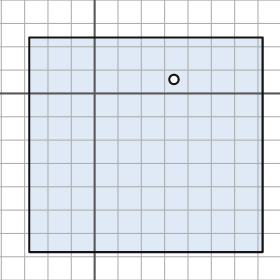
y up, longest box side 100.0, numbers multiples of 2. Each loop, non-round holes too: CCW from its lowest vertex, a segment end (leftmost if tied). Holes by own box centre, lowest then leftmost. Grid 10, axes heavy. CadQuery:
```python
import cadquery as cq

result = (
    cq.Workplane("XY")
    .moveTo(-28.0, -68.0)
    .lineTo(72.0, -68.0)
    .lineTo(72.0, 24.0)
    .lineTo(-28.0, 24.0)
    .close()
    .moveTo(34.0, 6.0)
    .circle(2.0)
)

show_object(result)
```